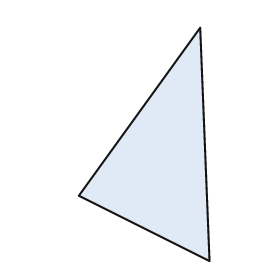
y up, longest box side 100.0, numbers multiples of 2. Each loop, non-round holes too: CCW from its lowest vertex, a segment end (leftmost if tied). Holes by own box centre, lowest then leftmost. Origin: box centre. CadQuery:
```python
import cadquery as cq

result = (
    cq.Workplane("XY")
    .moveTo(28.0, -50.0)
    .lineTo(24.0, 50.0)
    .lineTo(-28.0, -22.0)
    .close()
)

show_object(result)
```